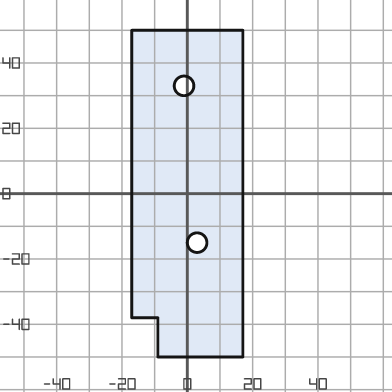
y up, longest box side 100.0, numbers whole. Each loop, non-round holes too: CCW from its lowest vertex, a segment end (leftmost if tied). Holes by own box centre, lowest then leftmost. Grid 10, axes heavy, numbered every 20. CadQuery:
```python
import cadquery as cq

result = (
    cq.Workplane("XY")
    .moveTo(-9.0, -50.0)
    .lineTo(17.0, -50.0)
    .lineTo(17.0, 50.0)
    .lineTo(-17.0, 50.0)
    .lineTo(-17.0, -38.0)
    .lineTo(-9.0, -38.0)
    .close()
    .moveTo(3.0, -15.0)
    .circle(3.0)
    .moveTo(-1.0, 33.0)
    .circle(3.0)
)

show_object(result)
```